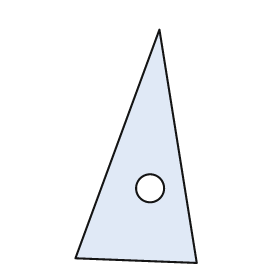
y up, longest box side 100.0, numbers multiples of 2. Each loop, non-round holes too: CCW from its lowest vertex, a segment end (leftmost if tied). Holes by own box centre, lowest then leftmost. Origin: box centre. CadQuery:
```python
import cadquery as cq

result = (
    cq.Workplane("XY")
    .moveTo(26.0, -50.0)
    .lineTo(10.0, 50.0)
    .lineTo(-26.0, -48.0)
    .close()
    .moveTo(6.0, -18.0)
    .circle(6.0)
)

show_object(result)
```